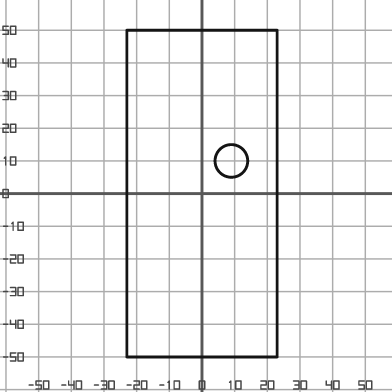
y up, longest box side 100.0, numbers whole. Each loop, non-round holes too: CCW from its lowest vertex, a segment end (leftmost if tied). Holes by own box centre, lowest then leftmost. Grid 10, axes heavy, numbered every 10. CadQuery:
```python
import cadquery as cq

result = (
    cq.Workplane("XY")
    .moveTo(-23.0, -50.0)
    .lineTo(23.0, -50.0)
    .lineTo(23.0, 50.0)
    .lineTo(-23.0, 50.0)
    .close()
    .moveTo(9.0, 10.0)
    .circle(5.0)
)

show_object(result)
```